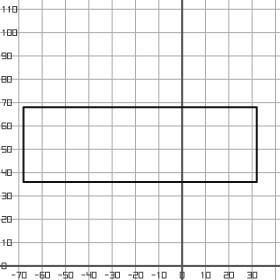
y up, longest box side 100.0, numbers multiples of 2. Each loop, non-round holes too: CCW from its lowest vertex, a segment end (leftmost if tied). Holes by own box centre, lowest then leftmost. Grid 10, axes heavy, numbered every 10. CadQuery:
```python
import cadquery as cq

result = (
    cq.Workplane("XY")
    .moveTo(-68.0, 36.0)
    .lineTo(32.0, 36.0)
    .lineTo(32.0, 68.0)
    .lineTo(-68.0, 68.0)
    .close()
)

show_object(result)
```